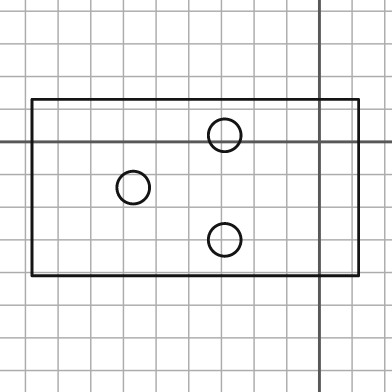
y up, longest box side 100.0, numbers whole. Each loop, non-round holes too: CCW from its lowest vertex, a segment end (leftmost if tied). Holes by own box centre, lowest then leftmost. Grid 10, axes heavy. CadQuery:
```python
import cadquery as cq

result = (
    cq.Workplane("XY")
    .moveTo(-88.0, -41.0)
    .lineTo(12.0, -41.0)
    .lineTo(12.0, 13.0)
    .lineTo(-88.0, 13.0)
    .close()
    .moveTo(-29.0, -30.0)
    .circle(5.0)
    .moveTo(-57.0, -14.0)
    .circle(5.0)
    .moveTo(-29.0, 2.0)
    .circle(5.0)
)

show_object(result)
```